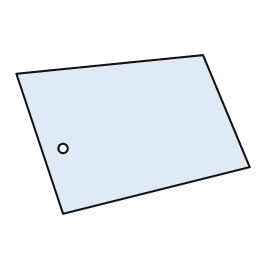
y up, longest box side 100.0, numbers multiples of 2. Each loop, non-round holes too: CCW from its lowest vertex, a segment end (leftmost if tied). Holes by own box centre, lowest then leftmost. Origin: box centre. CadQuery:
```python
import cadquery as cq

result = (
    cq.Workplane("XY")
    .moveTo(-30.0, -34.0)
    .lineTo(50.0, -14.0)
    .lineTo(30.0, 34.0)
    .lineTo(-50.0, 26.0)
    .close()
    .moveTo(-30.0, -6.0)
    .circle(2.0)
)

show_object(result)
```